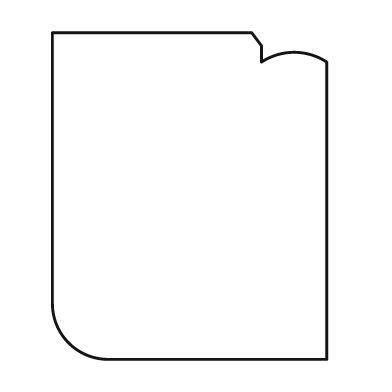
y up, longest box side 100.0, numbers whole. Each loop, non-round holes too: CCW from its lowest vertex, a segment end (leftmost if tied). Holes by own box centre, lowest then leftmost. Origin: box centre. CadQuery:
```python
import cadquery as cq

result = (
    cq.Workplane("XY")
    .moveTo(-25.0, -50.0)
    .lineTo(42.0, -50.0)
    .lineTo(42.0, 41.0)
    .threePointArc((32.0, 44.0), (22.0, 41.0))
    .lineTo(22.0, 46.0)
    .lineTo(19.0, 50.0)
    .lineTo(-42.0, 50.0)
    .lineTo(-42.0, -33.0)
    .threePointArc((-37.0, -45.0), (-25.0, -50.0))
    .close()
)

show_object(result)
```